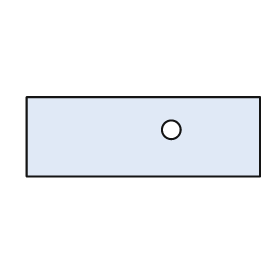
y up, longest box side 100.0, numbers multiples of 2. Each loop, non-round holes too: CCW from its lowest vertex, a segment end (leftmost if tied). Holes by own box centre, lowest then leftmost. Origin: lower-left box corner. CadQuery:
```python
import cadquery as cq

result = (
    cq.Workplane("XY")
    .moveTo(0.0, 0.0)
    .lineTo(100.0, 0.0)
    .lineTo(100.0, 34.0)
    .lineTo(0.0, 34.0)
    .close()
    .moveTo(62.0, 20.0)
    .circle(4.0)
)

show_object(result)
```